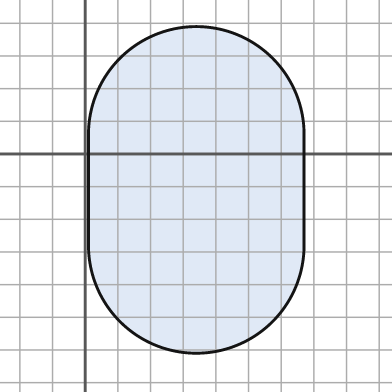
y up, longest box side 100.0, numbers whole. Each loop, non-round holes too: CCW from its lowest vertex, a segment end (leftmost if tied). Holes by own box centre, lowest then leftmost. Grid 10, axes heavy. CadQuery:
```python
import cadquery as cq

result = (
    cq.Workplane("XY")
    .moveTo(1.0, -28.0)
    .threePointArc((34.0, -61.0), (67.0, -28.0))
    .lineTo(67.0, 6.0)
    .threePointArc((34.0, 39.0), (1.0, 6.0))
    .close()
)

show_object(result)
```